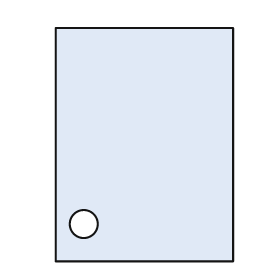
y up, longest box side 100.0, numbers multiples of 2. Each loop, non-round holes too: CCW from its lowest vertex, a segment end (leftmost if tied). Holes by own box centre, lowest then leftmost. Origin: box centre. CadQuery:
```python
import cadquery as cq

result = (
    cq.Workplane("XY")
    .moveTo(-38.0, -50.0)
    .lineTo(38.0, -50.0)
    .lineTo(38.0, 50.0)
    .lineTo(-38.0, 50.0)
    .close()
    .moveTo(-26.0, -34.0)
    .circle(6.0)
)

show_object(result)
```